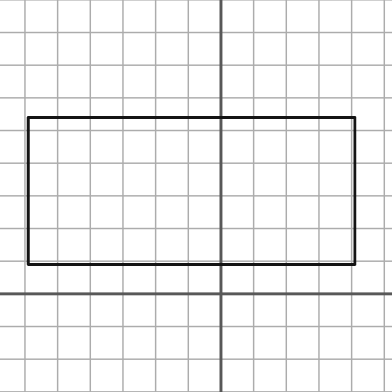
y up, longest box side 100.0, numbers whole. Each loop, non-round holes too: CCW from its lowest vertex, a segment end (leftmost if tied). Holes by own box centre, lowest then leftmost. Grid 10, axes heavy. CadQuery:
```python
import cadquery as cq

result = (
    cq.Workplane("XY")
    .moveTo(-59.0, 9.0)
    .lineTo(41.0, 9.0)
    .lineTo(41.0, 54.0)
    .lineTo(-59.0, 54.0)
    .close()
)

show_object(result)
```